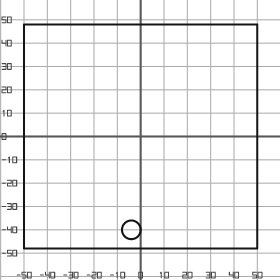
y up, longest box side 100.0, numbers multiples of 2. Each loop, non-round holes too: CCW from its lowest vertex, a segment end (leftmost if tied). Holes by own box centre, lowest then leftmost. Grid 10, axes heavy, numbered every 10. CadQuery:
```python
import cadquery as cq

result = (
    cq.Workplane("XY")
    .moveTo(-50.0, -48.0)
    .lineTo(50.0, -48.0)
    .lineTo(50.0, 48.0)
    .lineTo(-50.0, 48.0)
    .close()
    .moveTo(-4.0, -40.0)
    .circle(4.0)
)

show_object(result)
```